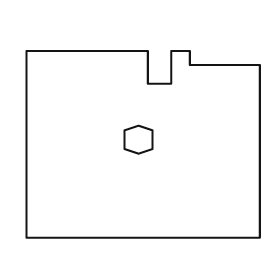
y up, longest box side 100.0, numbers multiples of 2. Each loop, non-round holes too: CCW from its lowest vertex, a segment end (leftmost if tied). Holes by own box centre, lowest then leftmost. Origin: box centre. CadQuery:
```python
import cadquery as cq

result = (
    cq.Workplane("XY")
    .moveTo(-50.0, -40.0)
    .lineTo(50.0, -40.0)
    .lineTo(50.0, 34.0)
    .lineTo(20.0, 34.0)
    .lineTo(20.0, 40.0)
    .lineTo(12.0, 40.0)
    .lineTo(12.0, 26.0)
    .lineTo(2.0, 26.0)
    .lineTo(2.0, 40.0)
    .lineTo(-50.0, 40.0)
    .close()
    .moveTo(-2.0, -4.0)
    .lineTo(4.0, -2.0)
    .lineTo(4.0, 6.0)
    .lineTo(-2.0, 8.0)
    .lineTo(-8.0, 6.0)
    .lineTo(-8.0, -2.0)
    .close()
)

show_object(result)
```